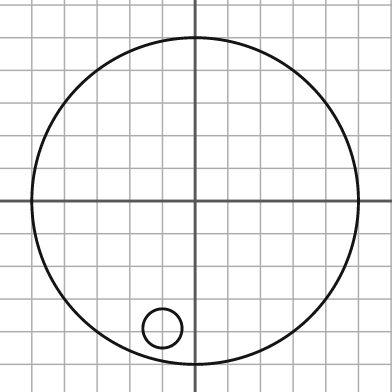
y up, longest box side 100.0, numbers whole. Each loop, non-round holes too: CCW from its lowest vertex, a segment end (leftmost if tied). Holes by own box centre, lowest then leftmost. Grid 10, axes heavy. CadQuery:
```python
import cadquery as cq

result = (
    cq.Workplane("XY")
    .moveTo(0.0, 0.0)
    .circle(50.0)
    .moveTo(-10.0, -39.0)
    .circle(6.0)
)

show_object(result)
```